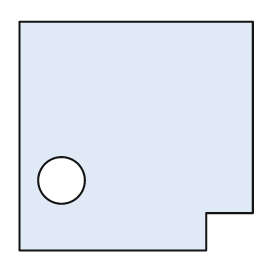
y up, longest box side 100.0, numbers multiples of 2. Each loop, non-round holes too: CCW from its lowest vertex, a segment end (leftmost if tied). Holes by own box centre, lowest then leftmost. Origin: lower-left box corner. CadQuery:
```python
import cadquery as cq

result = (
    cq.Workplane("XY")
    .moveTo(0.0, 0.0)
    .lineTo(80.0, 0.0)
    .lineTo(80.0, 16.0)
    .lineTo(100.0, 16.0)
    .lineTo(100.0, 98.0)
    .lineTo(0.0, 98.0)
    .close()
    .moveTo(18.0, 30.0)
    .circle(10.0)
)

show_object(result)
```